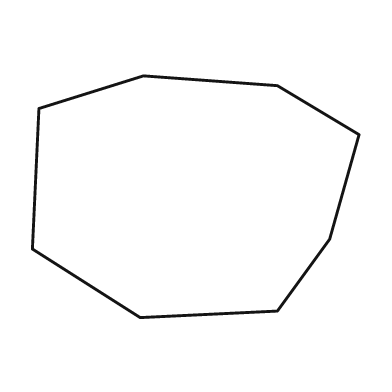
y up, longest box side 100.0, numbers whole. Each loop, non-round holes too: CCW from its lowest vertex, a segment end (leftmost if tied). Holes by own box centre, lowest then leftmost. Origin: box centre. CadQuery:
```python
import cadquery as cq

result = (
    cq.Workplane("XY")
    .moveTo(-17.0, -37.0)
    .lineTo(25.0, -35.0)
    .lineTo(41.0, -13.0)
    .lineTo(50.0, 19.0)
    .lineTo(25.0, 34.0)
    .lineTo(-16.0, 37.0)
    .lineTo(-48.0, 27.0)
    .lineTo(-50.0, -16.0)
    .close()
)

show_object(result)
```